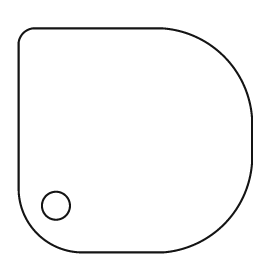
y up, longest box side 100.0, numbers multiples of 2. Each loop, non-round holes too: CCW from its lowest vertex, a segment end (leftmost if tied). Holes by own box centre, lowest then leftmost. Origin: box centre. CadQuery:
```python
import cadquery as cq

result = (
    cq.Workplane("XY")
    .moveTo(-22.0, -48.0)
    .lineTo(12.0, -48.0)
    .threePointArc((38.0, -36.0), (50.0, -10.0))
    .lineTo(50.0, 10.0)
    .threePointArc((38.0, 36.0), (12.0, 48.0))
    .lineTo(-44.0, 48.0)
    .threePointArc((-48.0, 46.0), (-50.0, 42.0))
    .lineTo(-50.0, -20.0)
    .threePointArc((-42.0, -40.0), (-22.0, -48.0))
    .close()
    .moveTo(-34.0, -28.0)
    .circle(6.0)
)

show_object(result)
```